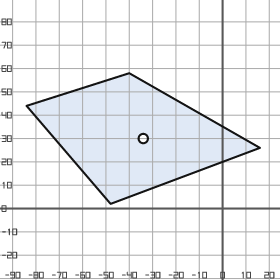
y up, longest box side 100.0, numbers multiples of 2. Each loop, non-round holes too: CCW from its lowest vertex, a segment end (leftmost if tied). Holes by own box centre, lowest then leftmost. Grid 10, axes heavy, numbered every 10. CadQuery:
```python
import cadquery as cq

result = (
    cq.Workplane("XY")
    .moveTo(-48.0, 2.0)
    .lineTo(16.0, 26.0)
    .lineTo(-40.0, 58.0)
    .lineTo(-84.0, 44.0)
    .close()
    .moveTo(-34.0, 30.0)
    .circle(2.0)
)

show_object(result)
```